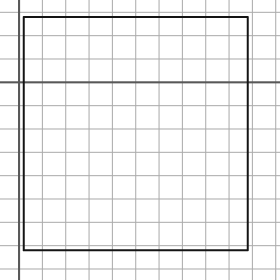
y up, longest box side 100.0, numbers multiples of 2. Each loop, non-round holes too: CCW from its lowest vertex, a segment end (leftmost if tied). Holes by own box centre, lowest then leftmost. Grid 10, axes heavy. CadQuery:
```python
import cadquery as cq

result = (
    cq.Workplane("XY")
    .moveTo(2.0, -72.0)
    .lineTo(98.0, -72.0)
    .lineTo(98.0, 28.0)
    .lineTo(2.0, 28.0)
    .close()
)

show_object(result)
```